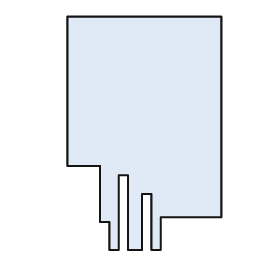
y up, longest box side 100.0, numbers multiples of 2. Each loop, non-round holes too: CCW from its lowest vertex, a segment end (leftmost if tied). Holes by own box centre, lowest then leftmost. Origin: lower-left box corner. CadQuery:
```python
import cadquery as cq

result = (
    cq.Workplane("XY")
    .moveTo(18.0, 0.0)
    .lineTo(22.0, 0.0)
    .lineTo(22.0, 32.0)
    .lineTo(26.0, 32.0)
    .lineTo(26.0, 0.0)
    .lineTo(32.0, 0.0)
    .lineTo(32.0, 24.0)
    .lineTo(36.0, 24.0)
    .lineTo(36.0, 0.0)
    .lineTo(40.0, 0.0)
    .lineTo(40.0, 14.0)
    .lineTo(66.0, 14.0)
    .lineTo(66.0, 100.0)
    .lineTo(0.0, 100.0)
    .lineTo(0.0, 36.0)
    .lineTo(14.0, 36.0)
    .lineTo(14.0, 12.0)
    .lineTo(18.0, 12.0)
    .close()
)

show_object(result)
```